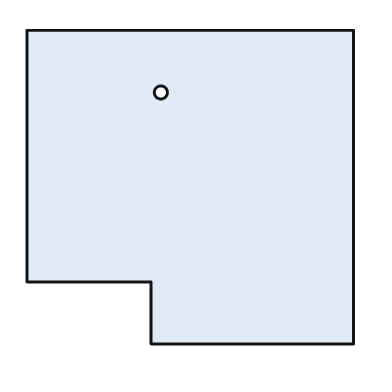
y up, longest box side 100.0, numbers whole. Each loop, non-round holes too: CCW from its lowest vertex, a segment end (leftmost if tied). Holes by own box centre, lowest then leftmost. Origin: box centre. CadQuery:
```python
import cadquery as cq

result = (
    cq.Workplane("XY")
    .moveTo(-12.0, -48.0)
    .lineTo(50.0, -48.0)
    .lineTo(50.0, 48.0)
    .lineTo(-50.0, 48.0)
    .lineTo(-50.0, -29.0)
    .lineTo(-12.0, -29.0)
    .close()
    .moveTo(-9.0, 29.0)
    .circle(2.0)
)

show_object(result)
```